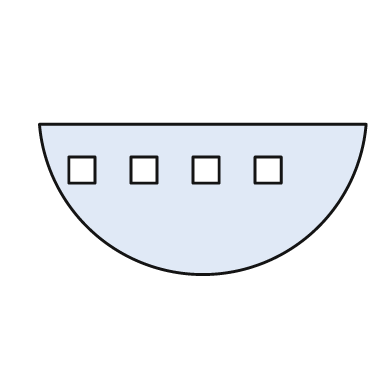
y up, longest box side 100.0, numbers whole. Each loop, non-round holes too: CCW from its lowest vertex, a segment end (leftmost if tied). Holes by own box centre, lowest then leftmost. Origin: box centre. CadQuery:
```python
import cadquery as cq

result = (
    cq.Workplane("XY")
    .moveTo(-50.0, 23.0)
    .threePointArc((0.0, -23.0), (50.0, 23.0))
    .close()
    .moveTo(-41.0, 5.0)
    .lineTo(-33.0, 5.0)
    .lineTo(-33.0, 13.0)
    .lineTo(-41.0, 13.0)
    .close()
    .moveTo(-22.0, 5.0)
    .lineTo(-14.0, 5.0)
    .lineTo(-14.0, 13.0)
    .lineTo(-22.0, 13.0)
    .close()
    .moveTo(-3.0, 5.0)
    .lineTo(5.0, 5.0)
    .lineTo(5.0, 13.0)
    .lineTo(-3.0, 13.0)
    .close()
    .moveTo(16.0, 5.0)
    .lineTo(24.0, 5.0)
    .lineTo(24.0, 13.0)
    .lineTo(16.0, 13.0)
    .close()
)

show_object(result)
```